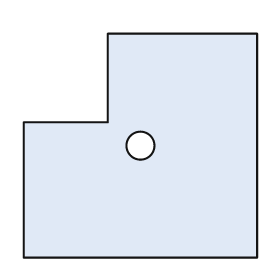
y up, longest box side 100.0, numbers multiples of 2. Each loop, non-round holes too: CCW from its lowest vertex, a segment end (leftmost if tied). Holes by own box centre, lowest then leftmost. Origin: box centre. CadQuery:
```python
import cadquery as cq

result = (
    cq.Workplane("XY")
    .moveTo(-50.0, -48.0)
    .lineTo(50.0, -48.0)
    .lineTo(50.0, 48.0)
    .lineTo(-14.0, 48.0)
    .lineTo(-14.0, 10.0)
    .lineTo(-50.0, 10.0)
    .close()
    .moveTo(0.0, 0.0)
    .circle(6.0)
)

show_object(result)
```